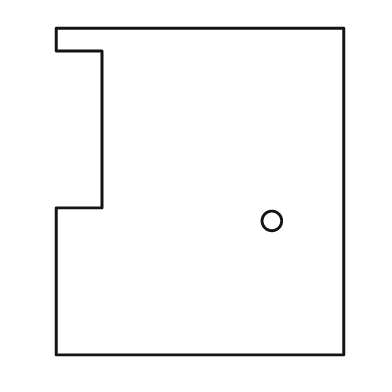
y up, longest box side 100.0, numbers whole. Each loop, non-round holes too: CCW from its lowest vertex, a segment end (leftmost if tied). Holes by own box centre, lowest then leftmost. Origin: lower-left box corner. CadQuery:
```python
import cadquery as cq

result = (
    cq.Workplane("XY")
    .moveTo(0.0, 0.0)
    .lineTo(88.0, 0.0)
    .lineTo(88.0, 100.0)
    .lineTo(0.0, 100.0)
    .lineTo(0.0, 93.0)
    .lineTo(14.0, 93.0)
    .lineTo(14.0, 45.0)
    .lineTo(0.0, 45.0)
    .close()
    .moveTo(66.0, 41.0)
    .circle(3.0)
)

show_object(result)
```